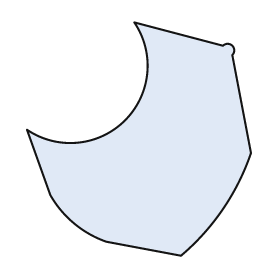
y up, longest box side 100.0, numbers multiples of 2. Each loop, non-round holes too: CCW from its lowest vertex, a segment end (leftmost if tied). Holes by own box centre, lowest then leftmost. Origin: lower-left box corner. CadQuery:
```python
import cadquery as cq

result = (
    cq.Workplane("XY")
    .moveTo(66.0, 0.0)
    .threePointArc((84.0, 20.0), (96.0, 44.0))
    .lineTo(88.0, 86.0)
    .threePointArc((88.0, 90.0), (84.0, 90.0))
    .lineTo(46.0, 100.0)
    .threePointArc((42.0, 58.0), (0.0, 54.0))
    .lineTo(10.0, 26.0)
    .threePointArc((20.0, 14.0), (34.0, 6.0))
    .close()
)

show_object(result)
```